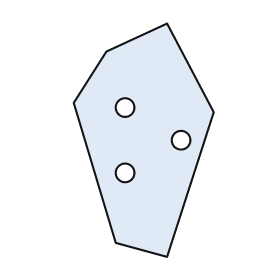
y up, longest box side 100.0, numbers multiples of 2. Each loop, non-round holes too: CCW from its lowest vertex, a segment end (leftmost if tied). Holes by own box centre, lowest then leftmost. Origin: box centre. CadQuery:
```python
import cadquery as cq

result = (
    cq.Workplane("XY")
    .moveTo(10.0, -50.0)
    .lineTo(30.0, 12.0)
    .lineTo(10.0, 50.0)
    .lineTo(-16.0, 38.0)
    .lineTo(-30.0, 16.0)
    .lineTo(-12.0, -44.0)
    .close()
    .moveTo(-8.0, -14.0)
    .circle(4.0)
    .moveTo(16.0, 0.0)
    .circle(4.0)
    .moveTo(-8.0, 14.0)
    .circle(4.0)
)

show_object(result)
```